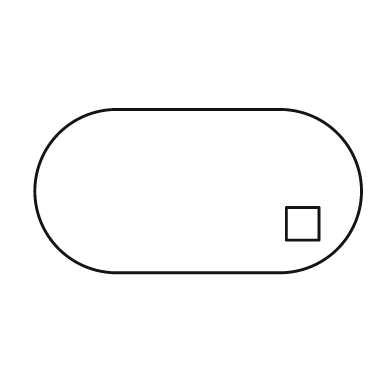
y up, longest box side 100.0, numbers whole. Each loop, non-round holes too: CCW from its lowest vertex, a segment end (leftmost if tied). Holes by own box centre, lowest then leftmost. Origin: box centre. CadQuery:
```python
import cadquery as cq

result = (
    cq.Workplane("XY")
    .moveTo(-25.0, -25.0)
    .lineTo(25.0, -25.0)
    .threePointArc((50.0, 0.0), (25.0, 25.0))
    .lineTo(-25.0, 25.0)
    .threePointArc((-50.0, 0.0), (-25.0, -25.0))
    .close()
    .moveTo(27.0, -15.0)
    .lineTo(37.0, -15.0)
    .lineTo(37.0, -5.0)
    .lineTo(27.0, -5.0)
    .close()
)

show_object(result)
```